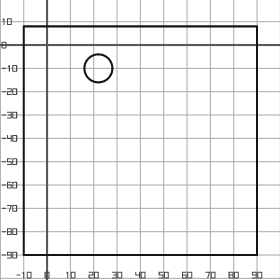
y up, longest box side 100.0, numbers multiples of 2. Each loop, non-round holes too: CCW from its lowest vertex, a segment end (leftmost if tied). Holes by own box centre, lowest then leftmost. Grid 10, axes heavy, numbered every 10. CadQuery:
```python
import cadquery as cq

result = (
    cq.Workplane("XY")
    .moveTo(-10.0, -90.0)
    .lineTo(90.0, -90.0)
    .lineTo(90.0, 8.0)
    .lineTo(-10.0, 8.0)
    .close()
    .moveTo(22.0, -10.0)
    .circle(6.0)
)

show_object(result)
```